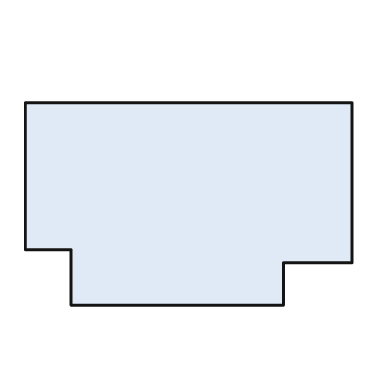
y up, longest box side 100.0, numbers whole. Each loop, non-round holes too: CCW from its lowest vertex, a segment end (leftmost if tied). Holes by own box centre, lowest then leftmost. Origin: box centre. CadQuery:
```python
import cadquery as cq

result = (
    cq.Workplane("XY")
    .moveTo(-36.0, -31.0)
    .lineTo(29.0, -31.0)
    .lineTo(29.0, -18.0)
    .lineTo(50.0, -18.0)
    .lineTo(50.0, 31.0)
    .lineTo(-50.0, 31.0)
    .lineTo(-50.0, -14.0)
    .lineTo(-36.0, -14.0)
    .close()
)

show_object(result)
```